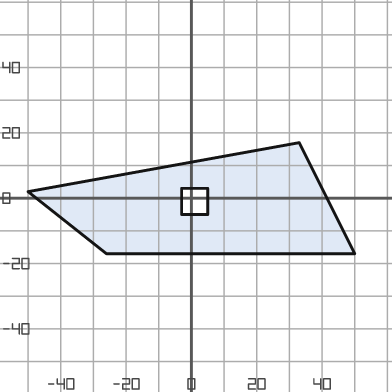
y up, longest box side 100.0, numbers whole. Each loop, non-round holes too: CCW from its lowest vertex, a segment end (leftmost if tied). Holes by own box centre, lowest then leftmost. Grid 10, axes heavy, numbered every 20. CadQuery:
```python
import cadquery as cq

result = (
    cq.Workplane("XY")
    .moveTo(-26.0, -17.0)
    .lineTo(50.0, -17.0)
    .lineTo(33.0, 17.0)
    .lineTo(-50.0, 2.0)
    .close()
    .moveTo(-3.0, -5.0)
    .lineTo(5.0, -5.0)
    .lineTo(5.0, 3.0)
    .lineTo(-3.0, 3.0)
    .close()
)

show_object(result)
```